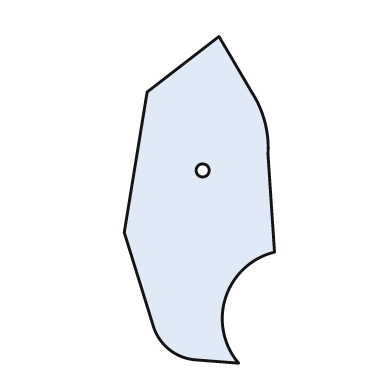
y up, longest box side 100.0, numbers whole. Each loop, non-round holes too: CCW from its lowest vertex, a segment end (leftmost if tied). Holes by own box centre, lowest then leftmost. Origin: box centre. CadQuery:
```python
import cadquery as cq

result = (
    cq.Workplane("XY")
    .moveTo(12.0, -50.0)
    .threePointArc((8.0, -30.0), (23.0, -16.0))
    .lineTo(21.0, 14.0)
    .threePointArc((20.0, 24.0), (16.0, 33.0))
    .lineTo(6.0, 50.0)
    .lineTo(-16.0, 33.0)
    .lineTo(-23.0, -10.0)
    .lineTo(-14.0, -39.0)
    .threePointArc((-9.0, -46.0), (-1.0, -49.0))
    .close()
    .moveTo(1.0, 9.0)
    .circle(2.0)
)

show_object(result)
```